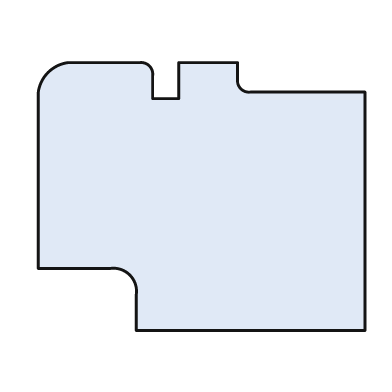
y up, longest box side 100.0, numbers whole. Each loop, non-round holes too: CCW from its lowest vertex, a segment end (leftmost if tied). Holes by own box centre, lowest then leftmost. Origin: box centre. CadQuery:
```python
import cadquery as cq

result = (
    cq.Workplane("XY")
    .moveTo(-20.0, -41.0)
    .lineTo(50.0, -41.0)
    .lineTo(50.0, 32.0)
    .lineTo(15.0, 32.0)
    .threePointArc((12.0, 33.0), (11.0, 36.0))
    .lineTo(11.0, 41.0)
    .lineTo(-7.0, 41.0)
    .lineTo(-7.0, 30.0)
    .lineTo(-15.0, 30.0)
    .lineTo(-15.0, 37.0)
    .threePointArc((-16.0, 40.0), (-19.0, 41.0))
    .lineTo(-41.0, 41.0)
    .threePointArc((-47.0, 38.0), (-50.0, 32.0))
    .lineTo(-50.0, -22.0)
    .lineTo(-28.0, -22.0)
    .threePointArc((-22.0, -24.0), (-20.0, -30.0))
    .close()
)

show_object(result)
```